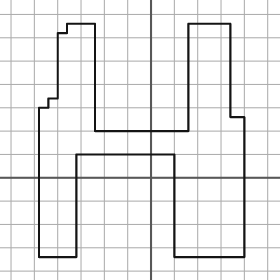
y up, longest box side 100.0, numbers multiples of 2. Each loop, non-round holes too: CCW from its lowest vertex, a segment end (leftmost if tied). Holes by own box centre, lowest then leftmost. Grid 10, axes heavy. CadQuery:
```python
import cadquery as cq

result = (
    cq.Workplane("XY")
    .moveTo(-48.0, -34.0)
    .lineTo(-32.0, -34.0)
    .lineTo(-32.0, 10.0)
    .lineTo(10.0, 10.0)
    .lineTo(10.0, -34.0)
    .lineTo(40.0, -34.0)
    .lineTo(40.0, 26.0)
    .lineTo(34.0, 26.0)
    .lineTo(34.0, 66.0)
    .lineTo(16.0, 66.0)
    .lineTo(16.0, 20.0)
    .lineTo(-24.0, 20.0)
    .lineTo(-24.0, 66.0)
    .lineTo(-36.0, 66.0)
    .lineTo(-36.0, 62.0)
    .lineTo(-40.0, 62.0)
    .lineTo(-40.0, 34.0)
    .lineTo(-44.0, 34.0)
    .lineTo(-44.0, 30.0)
    .lineTo(-48.0, 30.0)
    .close()
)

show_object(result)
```